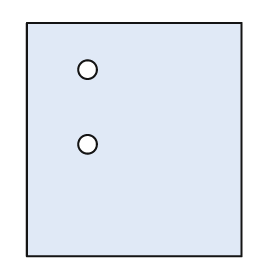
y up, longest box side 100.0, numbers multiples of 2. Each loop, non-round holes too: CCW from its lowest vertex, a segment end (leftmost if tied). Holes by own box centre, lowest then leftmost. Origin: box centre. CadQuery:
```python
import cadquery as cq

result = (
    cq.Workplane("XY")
    .moveTo(-46.0, -50.0)
    .lineTo(46.0, -50.0)
    .lineTo(46.0, 50.0)
    .lineTo(-46.0, 50.0)
    .close()
    .moveTo(-20.0, -2.0)
    .circle(4.0)
    .moveTo(-20.0, 30.0)
    .circle(4.0)
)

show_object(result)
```